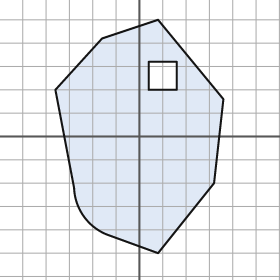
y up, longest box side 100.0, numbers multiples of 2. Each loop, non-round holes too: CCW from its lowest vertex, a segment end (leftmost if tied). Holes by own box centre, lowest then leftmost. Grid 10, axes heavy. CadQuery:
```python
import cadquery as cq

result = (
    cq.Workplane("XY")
    .moveTo(8.0, -50.0)
    .lineTo(32.0, -20.0)
    .lineTo(36.0, 16.0)
    .lineTo(8.0, 50.0)
    .lineTo(-16.0, 42.0)
    .lineTo(-36.0, 20.0)
    .lineTo(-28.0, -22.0)
    .threePointArc((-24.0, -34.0), (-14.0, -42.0))
    .close()
    .moveTo(4.0, 20.0)
    .lineTo(16.0, 20.0)
    .lineTo(16.0, 32.0)
    .lineTo(4.0, 32.0)
    .close()
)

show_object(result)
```